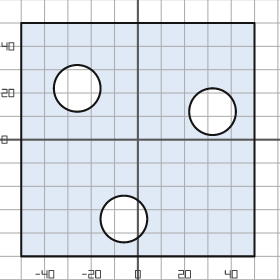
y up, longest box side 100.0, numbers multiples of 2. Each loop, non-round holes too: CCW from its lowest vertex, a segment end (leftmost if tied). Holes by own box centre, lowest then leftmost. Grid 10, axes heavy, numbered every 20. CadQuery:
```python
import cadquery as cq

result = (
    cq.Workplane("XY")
    .moveTo(-50.0, -50.0)
    .lineTo(50.0, -50.0)
    .lineTo(50.0, 50.0)
    .lineTo(-50.0, 50.0)
    .close()
    .moveTo(-6.0, -34.0)
    .circle(10.0)
    .moveTo(32.0, 12.0)
    .circle(10.0)
    .moveTo(-26.0, 22.0)
    .circle(10.0)
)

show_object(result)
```